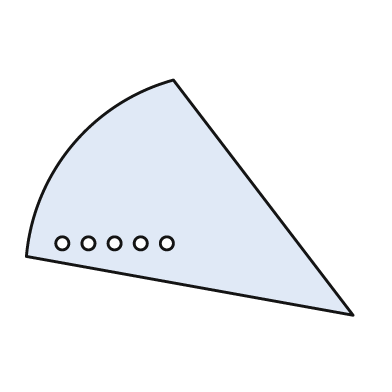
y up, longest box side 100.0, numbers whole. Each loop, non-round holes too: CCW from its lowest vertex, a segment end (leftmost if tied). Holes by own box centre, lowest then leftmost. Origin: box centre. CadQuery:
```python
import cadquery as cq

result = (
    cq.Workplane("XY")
    .moveTo(50.0, -36.0)
    .lineTo(-5.0, 36.0)
    .threePointArc((-36.0, 16.0), (-50.0, -18.0))
    .close()
    .moveTo(-39.0, -14.0)
    .circle(2.0)
    .moveTo(-31.0, -14.0)
    .circle(2.0)
    .moveTo(-23.0, -14.0)
    .circle(2.0)
    .moveTo(-15.0, -14.0)
    .circle(2.0)
    .moveTo(-7.0, -14.0)
    .circle(2.0)
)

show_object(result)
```